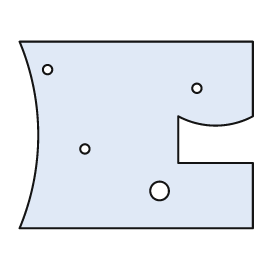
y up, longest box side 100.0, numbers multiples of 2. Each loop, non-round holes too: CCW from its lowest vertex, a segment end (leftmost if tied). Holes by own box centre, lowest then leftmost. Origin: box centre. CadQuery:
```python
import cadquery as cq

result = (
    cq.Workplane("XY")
    .moveTo(-50.0, -40.0)
    .lineTo(50.0, -40.0)
    .lineTo(50.0, -12.0)
    .lineTo(18.0, -12.0)
    .lineTo(18.0, 8.0)
    .threePointArc((34.0, 4.0), (50.0, 8.0))
    .lineTo(50.0, 40.0)
    .lineTo(-50.0, 40.0)
    .threePointArc((-42.0, 0.0), (-50.0, -40.0))
    .close()
    .moveTo(10.0, -24.0)
    .circle(4.0)
    .moveTo(-22.0, -6.0)
    .circle(2.0)
    .moveTo(26.0, 20.0)
    .circle(2.0)
    .moveTo(-38.0, 28.0)
    .circle(2.0)
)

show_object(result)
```